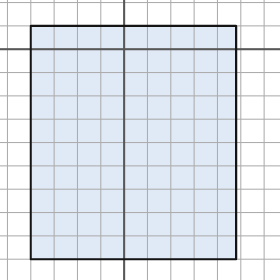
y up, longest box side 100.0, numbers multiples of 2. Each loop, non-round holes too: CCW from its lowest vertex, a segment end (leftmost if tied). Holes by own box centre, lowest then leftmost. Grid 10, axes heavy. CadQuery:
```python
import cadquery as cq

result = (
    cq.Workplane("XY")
    .moveTo(-40.0, -90.0)
    .lineTo(48.0, -90.0)
    .lineTo(48.0, 10.0)
    .lineTo(-40.0, 10.0)
    .close()
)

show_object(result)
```